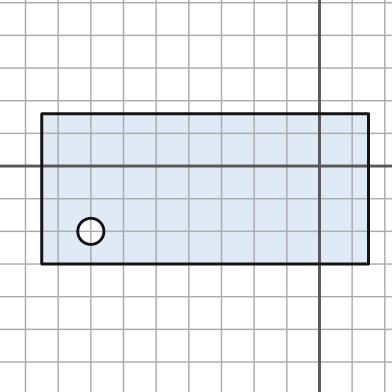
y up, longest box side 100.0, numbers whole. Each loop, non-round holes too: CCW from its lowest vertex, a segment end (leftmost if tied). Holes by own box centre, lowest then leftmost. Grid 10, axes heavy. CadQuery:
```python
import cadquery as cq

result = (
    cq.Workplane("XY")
    .moveTo(-85.0, -30.0)
    .lineTo(15.0, -30.0)
    .lineTo(15.0, 16.0)
    .lineTo(-85.0, 16.0)
    .close()
    .moveTo(-70.0, -20.0)
    .circle(4.0)
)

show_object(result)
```